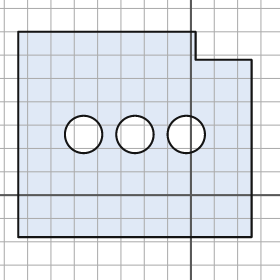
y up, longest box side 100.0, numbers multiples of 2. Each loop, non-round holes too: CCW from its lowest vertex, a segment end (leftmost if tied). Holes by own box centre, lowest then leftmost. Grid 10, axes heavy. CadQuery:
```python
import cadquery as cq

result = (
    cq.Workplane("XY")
    .moveTo(-74.0, -18.0)
    .lineTo(26.0, -18.0)
    .lineTo(26.0, 58.0)
    .lineTo(2.0, 58.0)
    .lineTo(2.0, 70.0)
    .lineTo(-74.0, 70.0)
    .close()
    .moveTo(-46.0, 26.0)
    .circle(8.0)
    .moveTo(-24.0, 26.0)
    .circle(8.0)
    .moveTo(-2.0, 26.0)
    .circle(8.0)
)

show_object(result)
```